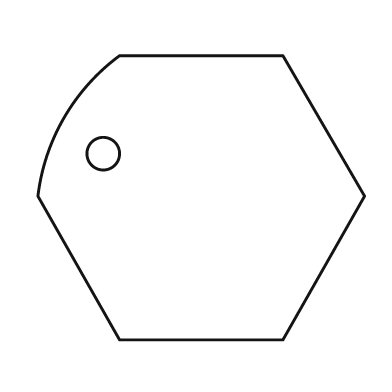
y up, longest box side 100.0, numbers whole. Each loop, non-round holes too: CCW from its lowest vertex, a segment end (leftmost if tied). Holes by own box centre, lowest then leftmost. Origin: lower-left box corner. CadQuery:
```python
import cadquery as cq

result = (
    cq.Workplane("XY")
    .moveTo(25.0, 0.0)
    .lineTo(75.0, 0.0)
    .lineTo(100.0, 44.0)
    .lineTo(75.0, 87.0)
    .lineTo(25.0, 87.0)
    .threePointArc((8.0, 68.0), (0.0, 44.0))
    .close()
    .moveTo(20.0, 57.0)
    .circle(5.0)
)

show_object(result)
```